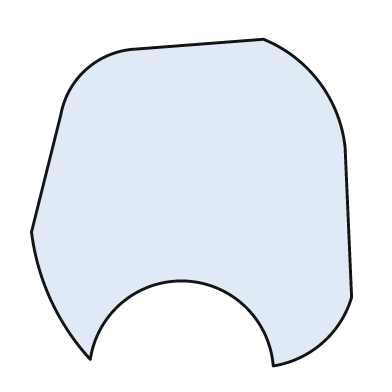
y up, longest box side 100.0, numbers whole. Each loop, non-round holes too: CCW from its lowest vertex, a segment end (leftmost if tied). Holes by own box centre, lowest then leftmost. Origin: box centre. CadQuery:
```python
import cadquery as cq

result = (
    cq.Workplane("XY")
    .moveTo(25.0, -50.0)
    .threePointArc((40.0, -43.0), (49.0, -29.0))
    .lineTo(47.0, 17.0)
    .threePointArc((39.0, 37.0), (22.0, 50.0))
    .lineTo(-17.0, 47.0)
    .threePointArc((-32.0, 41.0), (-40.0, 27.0))
    .lineTo(-49.0, -9.0)
    .threePointArc((-43.0, -30.0), (-31.0, -48.0))
    .threePointArc((-2.0, -24.0), (25.0, -50.0))
    .close()
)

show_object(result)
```